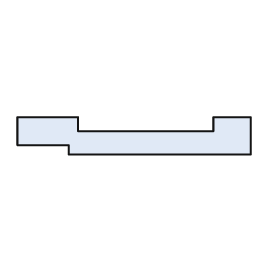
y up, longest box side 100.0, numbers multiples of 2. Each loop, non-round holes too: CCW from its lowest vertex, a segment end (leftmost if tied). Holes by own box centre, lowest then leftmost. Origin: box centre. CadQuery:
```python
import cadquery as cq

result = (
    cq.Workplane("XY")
    .moveTo(-28.0, -8.0)
    .lineTo(50.0, -8.0)
    .lineTo(50.0, 8.0)
    .lineTo(34.0, 8.0)
    .lineTo(34.0, 2.0)
    .lineTo(-24.0, 2.0)
    .lineTo(-24.0, 8.0)
    .lineTo(-50.0, 8.0)
    .lineTo(-50.0, -4.0)
    .lineTo(-28.0, -4.0)
    .close()
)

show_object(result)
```